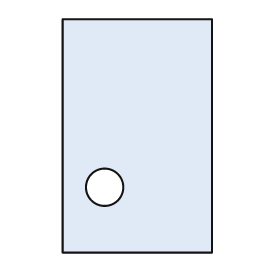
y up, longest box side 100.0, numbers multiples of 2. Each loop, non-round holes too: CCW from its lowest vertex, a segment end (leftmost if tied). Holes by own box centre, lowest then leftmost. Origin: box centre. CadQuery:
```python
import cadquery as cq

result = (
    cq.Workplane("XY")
    .moveTo(-32.0, -50.0)
    .lineTo(32.0, -50.0)
    .lineTo(32.0, 50.0)
    .lineTo(-32.0, 50.0)
    .close()
    .moveTo(-14.0, -22.0)
    .circle(8.0)
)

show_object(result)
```